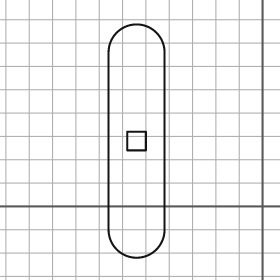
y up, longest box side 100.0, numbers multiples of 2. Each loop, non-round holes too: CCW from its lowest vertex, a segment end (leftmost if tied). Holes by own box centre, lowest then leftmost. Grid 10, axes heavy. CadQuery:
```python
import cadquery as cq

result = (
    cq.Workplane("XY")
    .moveTo(-66.0, -10.0)
    .threePointArc((-54.0, -22.0), (-42.0, -10.0))
    .lineTo(-42.0, 66.0)
    .threePointArc((-54.0, 78.0), (-66.0, 66.0))
    .close()
    .moveTo(-58.0, 24.0)
    .lineTo(-50.0, 24.0)
    .lineTo(-50.0, 32.0)
    .lineTo(-58.0, 32.0)
    .close()
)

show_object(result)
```